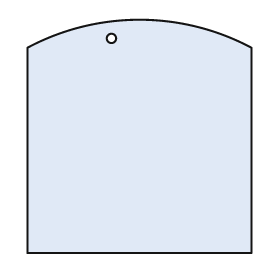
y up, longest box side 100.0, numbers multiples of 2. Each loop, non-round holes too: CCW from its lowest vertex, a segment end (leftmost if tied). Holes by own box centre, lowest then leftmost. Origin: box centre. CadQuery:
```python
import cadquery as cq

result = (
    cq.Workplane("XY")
    .moveTo(-48.0, -50.0)
    .lineTo(48.0, -50.0)
    .lineTo(48.0, 38.0)
    .threePointArc((0.0, 50.0), (-48.0, 38.0))
    .close()
    .moveTo(-12.0, 42.0)
    .circle(2.0)
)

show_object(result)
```